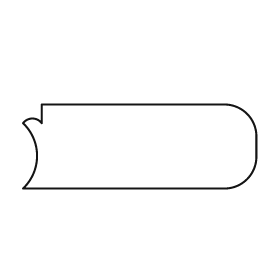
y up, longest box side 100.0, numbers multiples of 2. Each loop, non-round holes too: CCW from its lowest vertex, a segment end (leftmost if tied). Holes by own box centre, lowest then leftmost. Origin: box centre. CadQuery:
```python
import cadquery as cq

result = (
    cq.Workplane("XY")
    .moveTo(-50.0, -18.0)
    .lineTo(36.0, -18.0)
    .threePointArc((46.0, -14.0), (50.0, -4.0))
    .lineTo(50.0, 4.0)
    .threePointArc((46.0, 14.0), (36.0, 18.0))
    .lineTo(-42.0, 18.0)
    .lineTo(-42.0, 10.0)
    .threePointArc((-46.0, 12.0), (-50.0, 10.0))
    .threePointArc((-44.0, -4.0), (-50.0, -18.0))
    .close()
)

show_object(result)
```